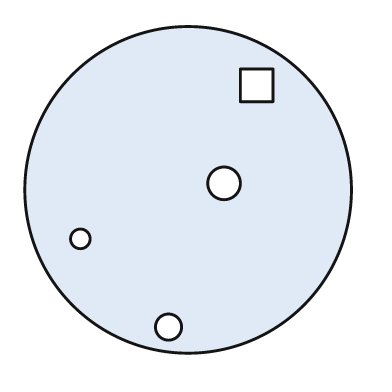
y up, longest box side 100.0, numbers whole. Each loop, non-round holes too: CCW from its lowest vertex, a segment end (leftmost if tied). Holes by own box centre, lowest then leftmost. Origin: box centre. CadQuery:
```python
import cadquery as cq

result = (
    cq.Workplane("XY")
    .moveTo(0.0, 0.0)
    .circle(50.0)
    .moveTo(-6.0, -42.0)
    .circle(4.0)
    .moveTo(-33.0, -15.0)
    .circle(3.0)
    .moveTo(11.0, 2.0)
    .circle(5.0)
    .moveTo(16.0, 27.0)
    .lineTo(26.0, 27.0)
    .lineTo(26.0, 37.0)
    .lineTo(16.0, 37.0)
    .close()
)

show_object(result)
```